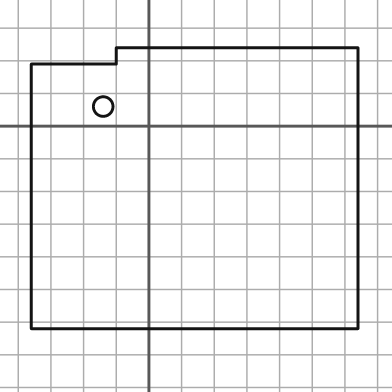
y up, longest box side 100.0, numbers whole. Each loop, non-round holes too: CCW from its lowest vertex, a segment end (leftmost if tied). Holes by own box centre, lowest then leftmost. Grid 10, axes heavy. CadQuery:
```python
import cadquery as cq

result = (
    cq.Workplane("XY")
    .moveTo(-36.0, -62.0)
    .lineTo(64.0, -62.0)
    .lineTo(64.0, 24.0)
    .lineTo(-10.0, 24.0)
    .lineTo(-10.0, 19.0)
    .lineTo(-36.0, 19.0)
    .close()
    .moveTo(-14.0, 6.0)
    .circle(3.0)
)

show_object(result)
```